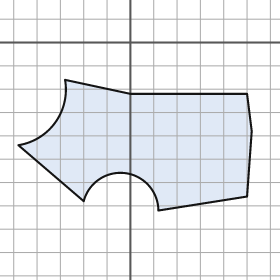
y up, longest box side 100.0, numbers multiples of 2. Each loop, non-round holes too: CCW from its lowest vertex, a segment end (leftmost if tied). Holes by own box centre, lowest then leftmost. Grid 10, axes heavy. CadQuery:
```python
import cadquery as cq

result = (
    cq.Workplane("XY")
    .moveTo(12.0, -72.0)
    .lineTo(50.0, -66.0)
    .lineTo(52.0, -38.0)
    .lineTo(50.0, -22.0)
    .lineTo(0.0, -22.0)
    .lineTo(-28.0, -16.0)
    .threePointArc((-32.0, -34.0), (-48.0, -44.0))
    .lineTo(-20.0, -68.0)
    .threePointArc((-2.0, -56.0), (12.0, -72.0))
    .close()
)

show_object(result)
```